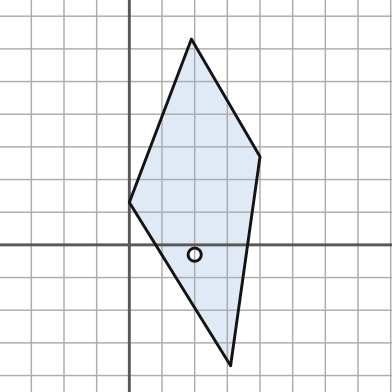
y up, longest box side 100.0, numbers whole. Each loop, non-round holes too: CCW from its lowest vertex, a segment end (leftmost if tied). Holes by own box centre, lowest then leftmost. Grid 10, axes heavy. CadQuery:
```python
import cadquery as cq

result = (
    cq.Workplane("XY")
    .moveTo(31.0, -37.0)
    .lineTo(40.0, 27.0)
    .lineTo(19.0, 63.0)
    .lineTo(0.0, 13.0)
    .close()
    .moveTo(20.0, -3.0)
    .circle(2.0)
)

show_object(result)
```